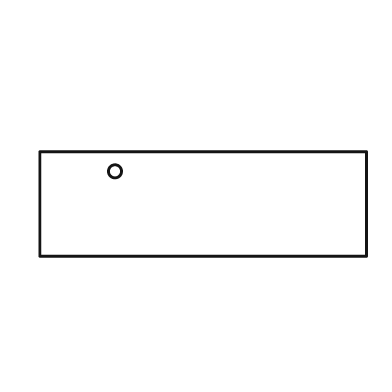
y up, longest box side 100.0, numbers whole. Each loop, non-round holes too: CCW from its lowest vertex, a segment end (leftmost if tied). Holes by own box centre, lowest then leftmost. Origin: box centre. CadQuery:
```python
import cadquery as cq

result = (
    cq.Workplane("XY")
    .moveTo(-50.0, -16.0)
    .lineTo(50.0, -16.0)
    .lineTo(50.0, 16.0)
    .lineTo(-50.0, 16.0)
    .close()
    .moveTo(-27.0, 10.0)
    .circle(2.0)
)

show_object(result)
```